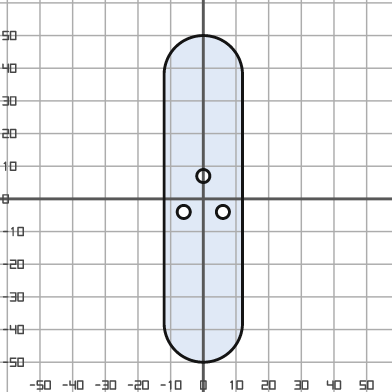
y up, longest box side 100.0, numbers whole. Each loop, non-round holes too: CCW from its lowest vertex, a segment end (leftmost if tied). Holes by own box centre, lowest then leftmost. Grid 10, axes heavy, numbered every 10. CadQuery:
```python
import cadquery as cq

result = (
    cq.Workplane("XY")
    .moveTo(-12.0, -38.0)
    .threePointArc((0.0, -50.0), (12.0, -38.0))
    .lineTo(12.0, 38.0)
    .threePointArc((0.0, 50.0), (-12.0, 38.0))
    .close()
    .moveTo(-6.0, -4.0)
    .circle(2.0)
    .moveTo(6.0, -4.0)
    .circle(2.0)
    .moveTo(0.0, 7.0)
    .circle(2.0)
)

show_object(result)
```